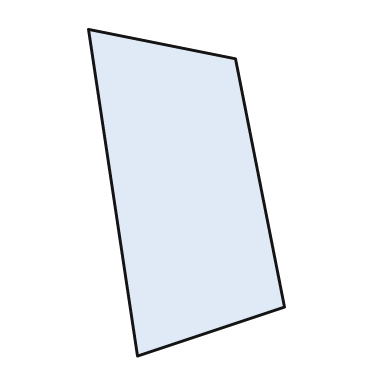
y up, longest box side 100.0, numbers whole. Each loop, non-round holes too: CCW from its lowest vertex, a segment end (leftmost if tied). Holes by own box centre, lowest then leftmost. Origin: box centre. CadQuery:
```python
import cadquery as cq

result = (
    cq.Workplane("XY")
    .moveTo(-15.0, -50.0)
    .lineTo(30.0, -35.0)
    .lineTo(15.0, 41.0)
    .lineTo(-30.0, 50.0)
    .close()
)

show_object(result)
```